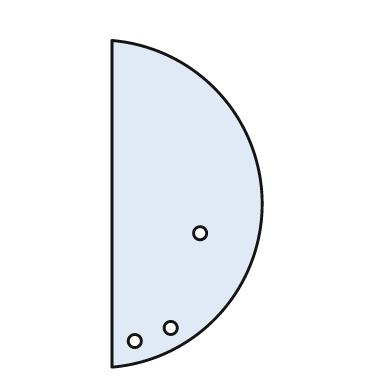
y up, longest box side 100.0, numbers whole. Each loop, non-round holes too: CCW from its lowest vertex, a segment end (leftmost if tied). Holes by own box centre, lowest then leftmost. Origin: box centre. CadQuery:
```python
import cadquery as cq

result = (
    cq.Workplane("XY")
    .moveTo(-23.0, -50.0)
    .threePointArc((23.0, 0.0), (-23.0, 50.0))
    .close()
    .moveTo(-16.0, -42.0)
    .circle(2.0)
    .moveTo(-5.0, -38.0)
    .circle(2.0)
    .moveTo(4.0, -9.0)
    .circle(2.0)
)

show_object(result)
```